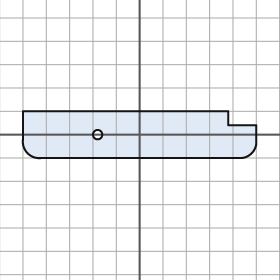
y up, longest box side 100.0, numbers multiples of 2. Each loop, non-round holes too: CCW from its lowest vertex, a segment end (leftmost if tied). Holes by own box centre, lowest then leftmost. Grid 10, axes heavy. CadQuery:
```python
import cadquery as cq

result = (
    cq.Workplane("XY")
    .moveTo(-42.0, -10.0)
    .lineTo(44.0, -10.0)
    .threePointArc((48.0, -8.0), (50.0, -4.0))
    .lineTo(50.0, 4.0)
    .lineTo(38.0, 4.0)
    .lineTo(38.0, 10.0)
    .lineTo(-50.0, 10.0)
    .lineTo(-50.0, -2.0)
    .threePointArc((-48.0, -8.0), (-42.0, -10.0))
    .close()
    .moveTo(-18.0, 0.0)
    .circle(2.0)
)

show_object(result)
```